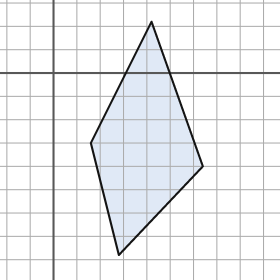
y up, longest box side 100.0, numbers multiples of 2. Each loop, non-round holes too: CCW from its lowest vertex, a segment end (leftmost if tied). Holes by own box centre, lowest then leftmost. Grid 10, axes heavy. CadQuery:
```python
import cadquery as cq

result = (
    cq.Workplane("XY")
    .moveTo(28.0, -78.0)
    .lineTo(64.0, -40.0)
    .lineTo(42.0, 22.0)
    .lineTo(16.0, -30.0)
    .close()
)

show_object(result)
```